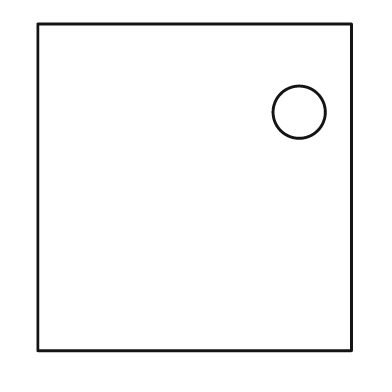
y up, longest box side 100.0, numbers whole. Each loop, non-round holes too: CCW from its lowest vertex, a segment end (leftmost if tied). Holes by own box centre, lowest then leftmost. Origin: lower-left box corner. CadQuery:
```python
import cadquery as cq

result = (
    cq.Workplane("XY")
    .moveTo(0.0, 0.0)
    .lineTo(96.0, 0.0)
    .lineTo(96.0, 100.0)
    .lineTo(0.0, 100.0)
    .close()
    .moveTo(80.0, 73.0)
    .circle(8.0)
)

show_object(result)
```